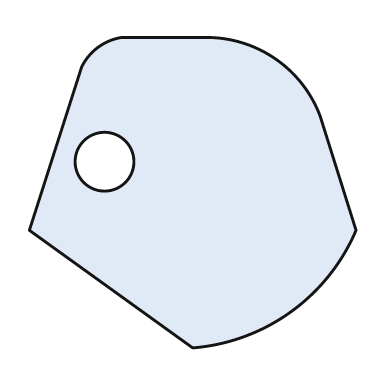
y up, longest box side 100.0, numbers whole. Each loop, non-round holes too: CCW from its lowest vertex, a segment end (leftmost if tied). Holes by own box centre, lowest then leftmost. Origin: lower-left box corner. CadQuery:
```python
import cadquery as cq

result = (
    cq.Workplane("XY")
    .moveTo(50.0, 0.0)
    .threePointArc((80.0, 11.0), (100.0, 36.0))
    .lineTo(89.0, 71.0)
    .threePointArc((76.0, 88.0), (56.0, 95.0))
    .lineTo(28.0, 95.0)
    .threePointArc((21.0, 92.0), (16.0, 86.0))
    .lineTo(0.0, 36.0)
    .close()
    .moveTo(23.0, 57.0)
    .circle(9.0)
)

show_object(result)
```